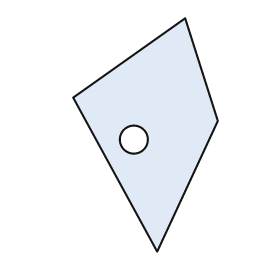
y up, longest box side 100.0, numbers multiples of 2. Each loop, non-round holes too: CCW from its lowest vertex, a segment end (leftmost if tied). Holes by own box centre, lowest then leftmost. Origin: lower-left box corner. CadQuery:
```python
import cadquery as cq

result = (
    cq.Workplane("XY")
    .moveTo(36.0, 0.0)
    .lineTo(62.0, 56.0)
    .lineTo(48.0, 100.0)
    .lineTo(0.0, 66.0)
    .close()
    .moveTo(26.0, 48.0)
    .circle(6.0)
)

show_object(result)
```